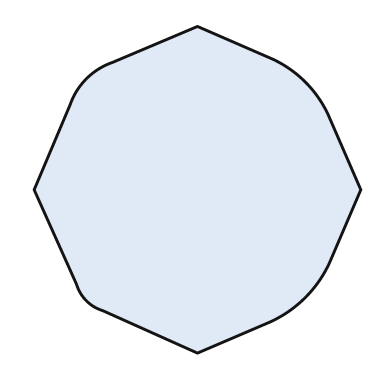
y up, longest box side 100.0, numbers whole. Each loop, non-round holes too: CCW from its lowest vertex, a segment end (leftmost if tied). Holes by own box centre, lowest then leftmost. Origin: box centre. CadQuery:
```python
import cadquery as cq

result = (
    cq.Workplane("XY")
    .moveTo(0.0, -50.0)
    .lineTo(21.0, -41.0)
    .threePointArc((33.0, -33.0), (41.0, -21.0))
    .lineTo(50.0, 0.0)
    .lineTo(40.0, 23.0)
    .threePointArc((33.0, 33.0), (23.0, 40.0))
    .lineTo(0.0, 50.0)
    .lineTo(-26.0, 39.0)
    .threePointArc((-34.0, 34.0), (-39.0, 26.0))
    .lineTo(-50.0, 0.0)
    .lineTo(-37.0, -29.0)
    .threePointArc((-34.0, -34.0), (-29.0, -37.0))
    .close()
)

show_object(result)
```